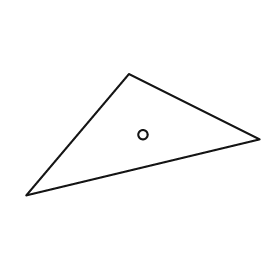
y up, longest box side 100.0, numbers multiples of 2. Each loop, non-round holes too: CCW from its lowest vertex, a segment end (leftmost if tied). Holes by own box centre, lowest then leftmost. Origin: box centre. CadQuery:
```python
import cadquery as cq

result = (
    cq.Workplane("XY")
    .moveTo(-50.0, -26.0)
    .lineTo(50.0, -2.0)
    .lineTo(-6.0, 26.0)
    .close()
    .moveTo(0.0, 0.0)
    .circle(2.0)
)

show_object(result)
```